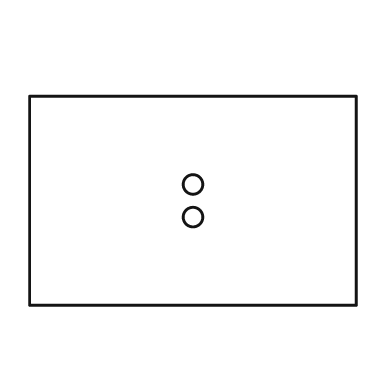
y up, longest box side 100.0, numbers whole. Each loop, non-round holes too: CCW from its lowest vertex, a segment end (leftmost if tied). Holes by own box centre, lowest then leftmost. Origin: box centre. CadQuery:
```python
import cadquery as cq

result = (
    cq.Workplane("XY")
    .moveTo(-50.0, -32.0)
    .lineTo(50.0, -32.0)
    .lineTo(50.0, 32.0)
    .lineTo(-50.0, 32.0)
    .close()
    .moveTo(0.0, -5.0)
    .circle(3.0)
    .moveTo(0.0, 5.0)
    .circle(3.0)
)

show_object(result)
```